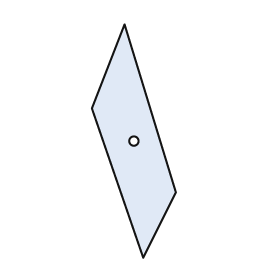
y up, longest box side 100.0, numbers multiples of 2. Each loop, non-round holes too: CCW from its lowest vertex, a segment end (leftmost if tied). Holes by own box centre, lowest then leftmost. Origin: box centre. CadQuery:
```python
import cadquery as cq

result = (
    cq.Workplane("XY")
    .moveTo(4.0, -50.0)
    .lineTo(18.0, -22.0)
    .lineTo(-4.0, 50.0)
    .lineTo(-18.0, 14.0)
    .close()
    .moveTo(0.0, 0.0)
    .circle(2.0)
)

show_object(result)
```